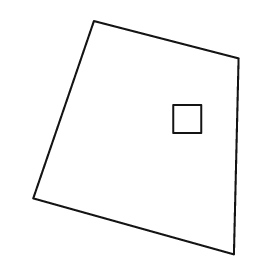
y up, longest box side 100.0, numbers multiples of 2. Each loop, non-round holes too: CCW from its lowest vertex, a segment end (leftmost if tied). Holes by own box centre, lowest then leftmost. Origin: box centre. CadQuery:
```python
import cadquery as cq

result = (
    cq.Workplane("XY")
    .moveTo(42.0, -50.0)
    .lineTo(44.0, 34.0)
    .lineTo(-18.0, 50.0)
    .lineTo(-44.0, -26.0)
    .close()
    .moveTo(16.0, 2.0)
    .lineTo(28.0, 2.0)
    .lineTo(28.0, 14.0)
    .lineTo(16.0, 14.0)
    .close()
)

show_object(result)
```